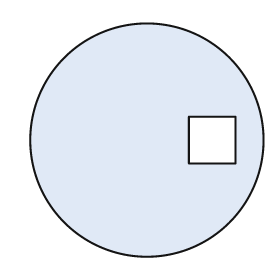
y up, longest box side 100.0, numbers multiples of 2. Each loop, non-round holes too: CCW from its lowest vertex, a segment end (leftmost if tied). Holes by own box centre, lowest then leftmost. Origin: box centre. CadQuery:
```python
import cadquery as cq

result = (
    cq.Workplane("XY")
    .moveTo(0.0, 0.0)
    .circle(50.0)
    .moveTo(18.0, -10.0)
    .lineTo(38.0, -10.0)
    .lineTo(38.0, 10.0)
    .lineTo(18.0, 10.0)
    .close()
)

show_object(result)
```